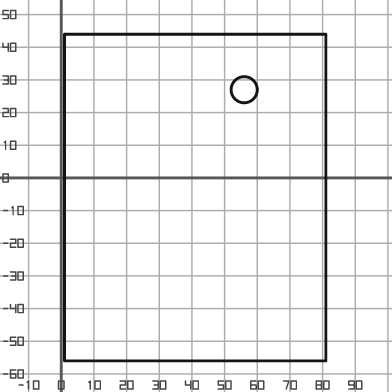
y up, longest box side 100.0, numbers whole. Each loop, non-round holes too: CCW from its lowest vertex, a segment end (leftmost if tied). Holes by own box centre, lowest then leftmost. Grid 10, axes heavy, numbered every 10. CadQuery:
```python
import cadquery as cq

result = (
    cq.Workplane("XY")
    .moveTo(1.0, -56.0)
    .lineTo(81.0, -56.0)
    .lineTo(81.0, 44.0)
    .lineTo(1.0, 44.0)
    .close()
    .moveTo(56.0, 27.0)
    .circle(4.0)
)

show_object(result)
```